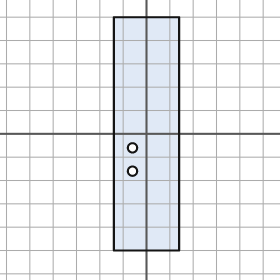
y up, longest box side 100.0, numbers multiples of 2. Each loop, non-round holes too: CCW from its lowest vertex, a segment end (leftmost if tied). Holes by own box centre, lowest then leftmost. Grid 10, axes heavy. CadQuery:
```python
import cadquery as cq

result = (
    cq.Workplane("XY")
    .moveTo(-14.0, -50.0)
    .lineTo(14.0, -50.0)
    .lineTo(14.0, 50.0)
    .lineTo(-14.0, 50.0)
    .close()
    .moveTo(-6.0, -16.0)
    .circle(2.0)
    .moveTo(-6.0, -6.0)
    .circle(2.0)
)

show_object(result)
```